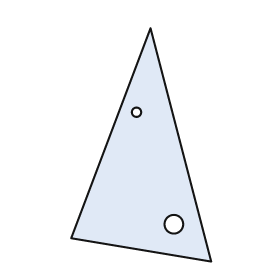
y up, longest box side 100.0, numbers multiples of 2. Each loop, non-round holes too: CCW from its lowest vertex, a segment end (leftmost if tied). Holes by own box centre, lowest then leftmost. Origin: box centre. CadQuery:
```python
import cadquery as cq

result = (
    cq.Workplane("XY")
    .moveTo(30.0, -50.0)
    .lineTo(4.0, 50.0)
    .lineTo(-30.0, -40.0)
    .close()
    .moveTo(14.0, -34.0)
    .circle(4.0)
    .moveTo(-2.0, 14.0)
    .circle(2.0)
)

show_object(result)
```